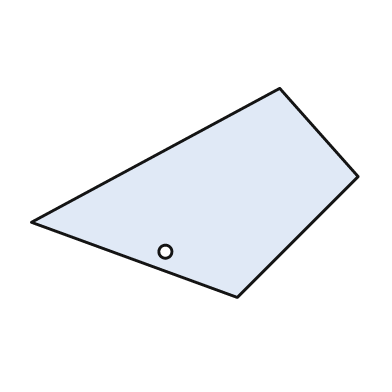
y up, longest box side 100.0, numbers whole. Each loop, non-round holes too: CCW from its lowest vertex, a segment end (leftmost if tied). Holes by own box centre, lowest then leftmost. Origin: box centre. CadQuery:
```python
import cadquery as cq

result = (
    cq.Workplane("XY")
    .moveTo(13.0, -32.0)
    .lineTo(50.0, 5.0)
    .lineTo(26.0, 32.0)
    .lineTo(-50.0, -9.0)
    .close()
    .moveTo(-9.0, -18.0)
    .circle(2.0)
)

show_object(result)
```